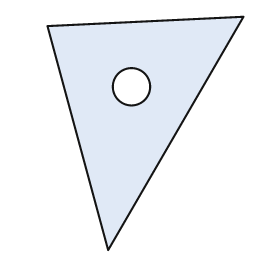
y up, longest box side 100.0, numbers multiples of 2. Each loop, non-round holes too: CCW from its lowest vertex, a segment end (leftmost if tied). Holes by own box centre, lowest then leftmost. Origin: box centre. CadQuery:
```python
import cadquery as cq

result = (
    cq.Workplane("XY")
    .moveTo(-16.0, -50.0)
    .lineTo(42.0, 50.0)
    .lineTo(-42.0, 46.0)
    .close()
    .moveTo(-6.0, 20.0)
    .circle(8.0)
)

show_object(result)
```